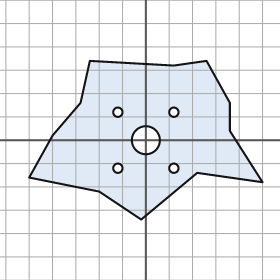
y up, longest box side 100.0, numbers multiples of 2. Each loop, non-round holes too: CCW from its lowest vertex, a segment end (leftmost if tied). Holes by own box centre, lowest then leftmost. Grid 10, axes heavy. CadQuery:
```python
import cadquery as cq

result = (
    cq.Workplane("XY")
    .moveTo(-2.0, -34.0)
    .lineTo(22.0, -14.0)
    .lineTo(50.0, -18.0)
    .lineTo(36.0, 4.0)
    .lineTo(36.0, 16.0)
    .lineTo(26.0, 34.0)
    .lineTo(12.0, 32.0)
    .lineTo(-24.0, 34.0)
    .lineTo(-28.0, 16.0)
    .lineTo(-40.0, 2.0)
    .lineTo(-50.0, -16.0)
    .lineTo(-20.0, -22.0)
    .close()
    .moveTo(-12.0, -12.0)
    .circle(2.0)
    .moveTo(12.0, -12.0)
    .circle(2.0)
    .moveTo(0.0, 0.0)
    .circle(6.0)
    .moveTo(-12.0, 12.0)
    .circle(2.0)
    .moveTo(12.0, 12.0)
    .circle(2.0)
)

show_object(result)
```